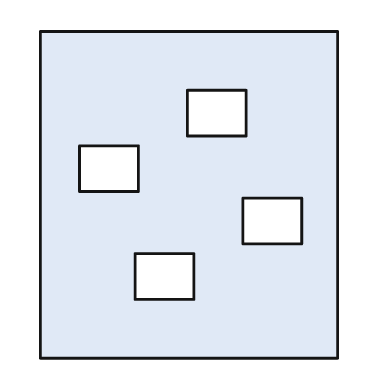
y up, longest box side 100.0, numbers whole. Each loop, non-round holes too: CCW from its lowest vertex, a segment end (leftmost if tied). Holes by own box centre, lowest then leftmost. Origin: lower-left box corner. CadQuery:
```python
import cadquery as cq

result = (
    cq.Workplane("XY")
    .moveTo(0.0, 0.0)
    .lineTo(91.0, 0.0)
    .lineTo(91.0, 100.0)
    .lineTo(0.0, 100.0)
    .close()
    .moveTo(29.0, 18.0)
    .lineTo(47.0, 18.0)
    .lineTo(47.0, 32.0)
    .lineTo(29.0, 32.0)
    .close()
    .moveTo(62.0, 35.0)
    .lineTo(80.0, 35.0)
    .lineTo(80.0, 49.0)
    .lineTo(62.0, 49.0)
    .close()
    .moveTo(12.0, 51.0)
    .lineTo(30.0, 51.0)
    .lineTo(30.0, 65.0)
    .lineTo(12.0, 65.0)
    .close()
    .moveTo(45.0, 68.0)
    .lineTo(63.0, 68.0)
    .lineTo(63.0, 82.0)
    .lineTo(45.0, 82.0)
    .close()
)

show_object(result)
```